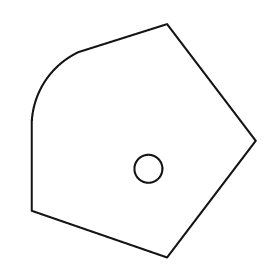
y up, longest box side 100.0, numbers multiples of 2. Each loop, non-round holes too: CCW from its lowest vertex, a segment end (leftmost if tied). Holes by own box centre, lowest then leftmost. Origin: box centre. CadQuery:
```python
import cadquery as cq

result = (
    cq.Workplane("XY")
    .moveTo(10.0, -50.0)
    .lineTo(48.0, 0.0)
    .lineTo(10.0, 50.0)
    .lineTo(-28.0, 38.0)
    .threePointArc((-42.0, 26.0), (-48.0, 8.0))
    .lineTo(-48.0, -30.0)
    .close()
    .moveTo(2.0, -12.0)
    .circle(6.0)
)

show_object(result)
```